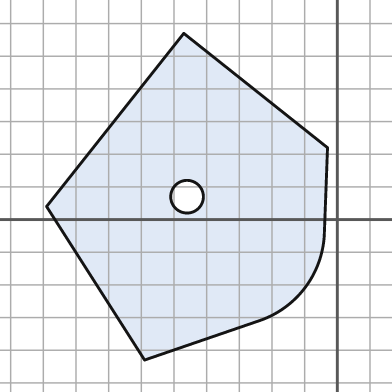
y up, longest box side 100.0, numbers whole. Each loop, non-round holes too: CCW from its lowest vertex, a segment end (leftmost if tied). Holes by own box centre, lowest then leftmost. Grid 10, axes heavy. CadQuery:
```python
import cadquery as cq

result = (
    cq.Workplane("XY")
    .moveTo(-59.0, -43.0)
    .lineTo(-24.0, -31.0)
    .threePointArc((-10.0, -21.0), (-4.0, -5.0))
    .lineTo(-3.0, 22.0)
    .lineTo(-47.0, 57.0)
    .lineTo(-89.0, 4.0)
    .close()
    .moveTo(-46.0, 7.0)
    .circle(5.0)
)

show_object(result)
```